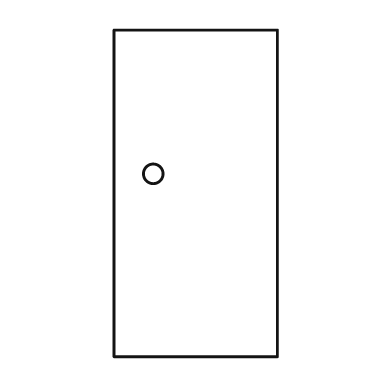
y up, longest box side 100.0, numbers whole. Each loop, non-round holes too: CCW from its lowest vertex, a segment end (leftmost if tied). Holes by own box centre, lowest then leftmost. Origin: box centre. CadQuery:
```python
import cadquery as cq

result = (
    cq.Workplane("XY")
    .moveTo(-25.0, -50.0)
    .lineTo(25.0, -50.0)
    .lineTo(25.0, 50.0)
    .lineTo(-25.0, 50.0)
    .close()
    .moveTo(-13.0, 6.0)
    .circle(3.0)
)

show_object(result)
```